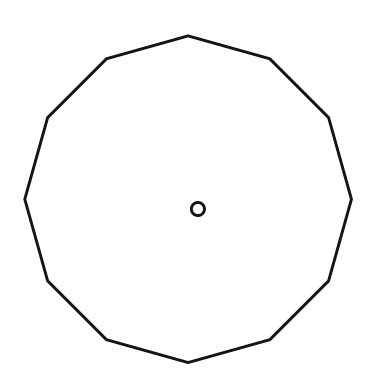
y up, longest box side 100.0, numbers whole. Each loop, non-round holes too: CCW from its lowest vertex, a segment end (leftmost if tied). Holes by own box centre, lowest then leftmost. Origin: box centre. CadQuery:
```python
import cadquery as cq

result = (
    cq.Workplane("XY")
    .moveTo(0.0, -50.0)
    .lineTo(25.0, -43.0)
    .lineTo(43.0, -25.0)
    .lineTo(50.0, 0.0)
    .lineTo(43.0, 25.0)
    .lineTo(25.0, 43.0)
    .lineTo(0.0, 50.0)
    .lineTo(-25.0, 43.0)
    .lineTo(-43.0, 25.0)
    .lineTo(-50.0, 0.0)
    .lineTo(-43.0, -25.0)
    .lineTo(-25.0, -43.0)
    .close()
    .moveTo(3.0, -3.0)
    .circle(2.0)
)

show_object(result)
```